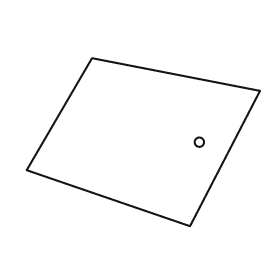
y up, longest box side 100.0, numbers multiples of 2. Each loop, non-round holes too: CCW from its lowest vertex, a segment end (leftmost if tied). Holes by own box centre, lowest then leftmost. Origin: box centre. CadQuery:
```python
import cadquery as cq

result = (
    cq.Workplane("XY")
    .moveTo(20.0, -36.0)
    .lineTo(50.0, 22.0)
    .lineTo(-22.0, 36.0)
    .lineTo(-50.0, -12.0)
    .close()
    .moveTo(24.0, 0.0)
    .circle(2.0)
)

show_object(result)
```